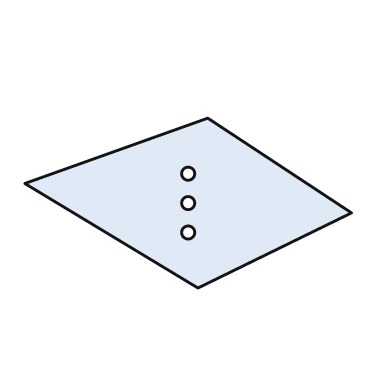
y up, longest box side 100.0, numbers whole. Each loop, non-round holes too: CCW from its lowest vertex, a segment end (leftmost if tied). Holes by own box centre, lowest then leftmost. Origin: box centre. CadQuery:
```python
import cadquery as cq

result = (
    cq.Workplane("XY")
    .moveTo(3.0, -26.0)
    .lineTo(50.0, -3.0)
    .lineTo(6.0, 26.0)
    .lineTo(-50.0, 6.0)
    .close()
    .moveTo(0.0, -9.0)
    .circle(2.0)
    .moveTo(0.0, 0.0)
    .circle(2.0)
    .moveTo(0.0, 9.0)
    .circle(2.0)
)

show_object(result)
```